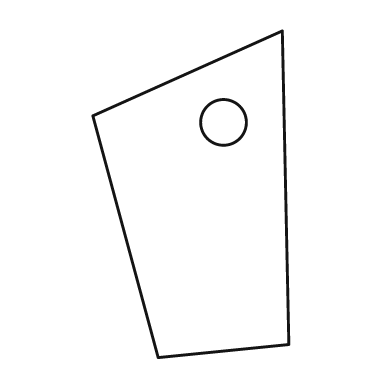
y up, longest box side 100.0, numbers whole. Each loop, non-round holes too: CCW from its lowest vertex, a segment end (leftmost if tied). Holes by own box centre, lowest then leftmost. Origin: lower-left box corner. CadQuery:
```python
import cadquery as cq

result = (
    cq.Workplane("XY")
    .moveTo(20.0, 0.0)
    .lineTo(60.0, 4.0)
    .lineTo(58.0, 100.0)
    .lineTo(0.0, 74.0)
    .close()
    .moveTo(40.0, 72.0)
    .circle(7.0)
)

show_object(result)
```